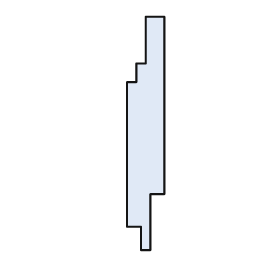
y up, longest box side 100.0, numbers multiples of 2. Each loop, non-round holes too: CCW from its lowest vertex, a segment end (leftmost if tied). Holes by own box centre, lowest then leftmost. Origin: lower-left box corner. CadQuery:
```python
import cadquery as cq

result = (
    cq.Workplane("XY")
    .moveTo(6.0, 0.0)
    .lineTo(10.0, 0.0)
    .lineTo(10.0, 24.0)
    .lineTo(16.0, 24.0)
    .lineTo(16.0, 100.0)
    .lineTo(8.0, 100.0)
    .lineTo(8.0, 80.0)
    .lineTo(4.0, 80.0)
    .lineTo(4.0, 72.0)
    .lineTo(0.0, 72.0)
    .lineTo(0.0, 10.0)
    .lineTo(6.0, 10.0)
    .close()
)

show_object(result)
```